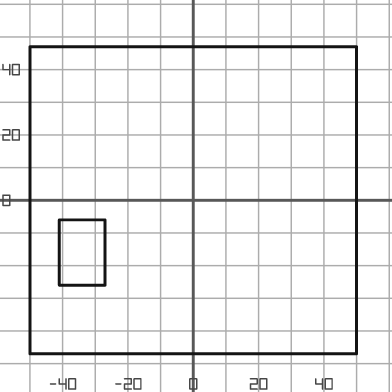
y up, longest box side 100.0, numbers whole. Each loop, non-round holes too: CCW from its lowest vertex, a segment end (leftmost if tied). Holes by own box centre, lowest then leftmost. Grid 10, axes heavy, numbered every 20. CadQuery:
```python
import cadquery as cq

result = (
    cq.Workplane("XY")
    .moveTo(-50.0, -47.0)
    .lineTo(50.0, -47.0)
    .lineTo(50.0, 47.0)
    .lineTo(-50.0, 47.0)
    .close()
    .moveTo(-41.0, -26.0)
    .lineTo(-27.0, -26.0)
    .lineTo(-27.0, -6.0)
    .lineTo(-41.0, -6.0)
    .close()
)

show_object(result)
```